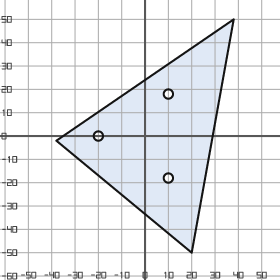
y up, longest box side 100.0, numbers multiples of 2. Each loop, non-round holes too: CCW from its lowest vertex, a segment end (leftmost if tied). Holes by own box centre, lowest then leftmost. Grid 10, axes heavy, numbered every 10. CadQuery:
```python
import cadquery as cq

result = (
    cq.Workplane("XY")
    .moveTo(20.0, -50.0)
    .lineTo(38.0, 50.0)
    .lineTo(-38.0, -2.0)
    .close()
    .moveTo(10.0, -18.0)
    .circle(2.0)
    .moveTo(-20.0, 0.0)
    .circle(2.0)
    .moveTo(10.0, 18.0)
    .circle(2.0)
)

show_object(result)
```